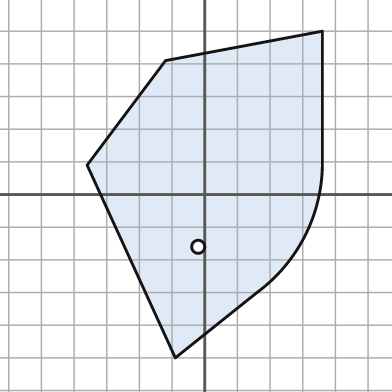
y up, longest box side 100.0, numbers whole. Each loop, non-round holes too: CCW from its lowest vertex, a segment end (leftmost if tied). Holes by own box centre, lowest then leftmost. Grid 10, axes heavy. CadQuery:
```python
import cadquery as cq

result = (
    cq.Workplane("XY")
    .moveTo(-9.0, -50.0)
    .lineTo(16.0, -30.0)
    .threePointArc((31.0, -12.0), (36.0, 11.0))
    .lineTo(36.0, 50.0)
    .lineTo(-12.0, 41.0)
    .lineTo(-36.0, 9.0)
    .close()
    .moveTo(-2.0, -16.0)
    .circle(2.0)
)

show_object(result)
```